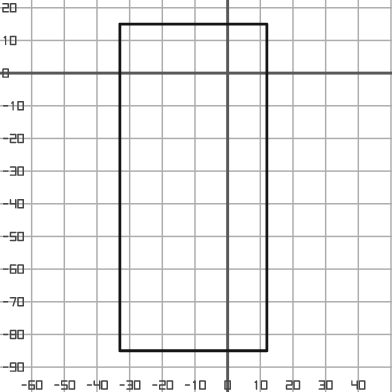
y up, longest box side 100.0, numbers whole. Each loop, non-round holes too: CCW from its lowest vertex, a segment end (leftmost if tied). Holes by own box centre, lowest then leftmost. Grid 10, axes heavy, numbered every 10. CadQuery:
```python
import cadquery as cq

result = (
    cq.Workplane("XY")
    .moveTo(-33.0, -85.0)
    .lineTo(12.0, -85.0)
    .lineTo(12.0, 15.0)
    .lineTo(-33.0, 15.0)
    .close()
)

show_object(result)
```